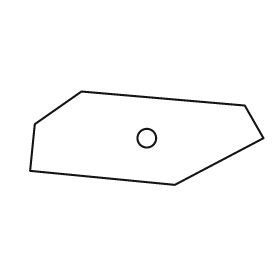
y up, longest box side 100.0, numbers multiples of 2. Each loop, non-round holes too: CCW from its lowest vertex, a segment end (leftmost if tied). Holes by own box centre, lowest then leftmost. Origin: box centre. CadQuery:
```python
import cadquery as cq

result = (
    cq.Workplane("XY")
    .moveTo(12.0, -20.0)
    .lineTo(50.0, 0.0)
    .lineTo(42.0, 14.0)
    .lineTo(-28.0, 20.0)
    .lineTo(-48.0, 6.0)
    .lineTo(-50.0, -14.0)
    .close()
    .moveTo(0.0, 0.0)
    .circle(4.0)
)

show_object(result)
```